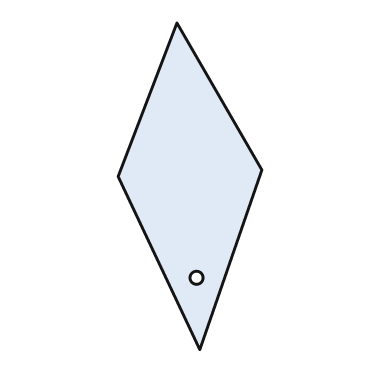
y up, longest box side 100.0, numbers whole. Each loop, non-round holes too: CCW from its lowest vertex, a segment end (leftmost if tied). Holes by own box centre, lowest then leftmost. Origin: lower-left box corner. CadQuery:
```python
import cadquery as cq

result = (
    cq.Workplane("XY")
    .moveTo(25.0, 0.0)
    .lineTo(44.0, 55.0)
    .lineTo(18.0, 100.0)
    .lineTo(0.0, 53.0)
    .close()
    .moveTo(24.0, 22.0)
    .circle(2.0)
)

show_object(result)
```